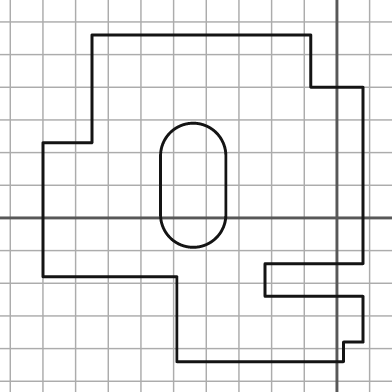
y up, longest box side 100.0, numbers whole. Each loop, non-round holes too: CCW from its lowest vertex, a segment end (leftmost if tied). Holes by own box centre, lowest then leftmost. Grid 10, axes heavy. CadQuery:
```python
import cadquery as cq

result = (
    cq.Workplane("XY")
    .moveTo(-49.0, -44.0)
    .lineTo(2.0, -44.0)
    .lineTo(2.0, -38.0)
    .lineTo(8.0, -38.0)
    .lineTo(8.0, -24.0)
    .lineTo(-22.0, -24.0)
    .lineTo(-22.0, -14.0)
    .lineTo(8.0, -14.0)
    .lineTo(8.0, 40.0)
    .lineTo(-8.0, 40.0)
    .lineTo(-8.0, 56.0)
    .lineTo(-75.0, 56.0)
    .lineTo(-75.0, 23.0)
    .lineTo(-90.0, 23.0)
    .lineTo(-90.0, -18.0)
    .lineTo(-49.0, -18.0)
    .close()
    .moveTo(-54.0, 1.0)
    .threePointArc((-44.0, -9.0), (-34.0, 1.0))
    .lineTo(-34.0, 19.0)
    .threePointArc((-44.0, 29.0), (-54.0, 19.0))
    .close()
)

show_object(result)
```